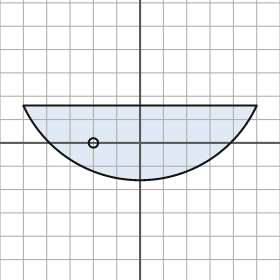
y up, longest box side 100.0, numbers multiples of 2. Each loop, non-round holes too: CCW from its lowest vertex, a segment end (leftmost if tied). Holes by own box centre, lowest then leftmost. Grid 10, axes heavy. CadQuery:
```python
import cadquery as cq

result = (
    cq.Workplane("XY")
    .moveTo(-50.0, 16.0)
    .threePointArc((0.0, -16.0), (50.0, 16.0))
    .close()
    .moveTo(-20.0, 0.0)
    .circle(2.0)
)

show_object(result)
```